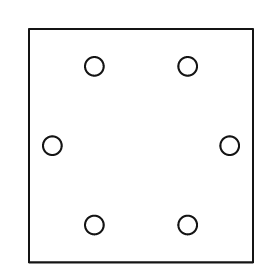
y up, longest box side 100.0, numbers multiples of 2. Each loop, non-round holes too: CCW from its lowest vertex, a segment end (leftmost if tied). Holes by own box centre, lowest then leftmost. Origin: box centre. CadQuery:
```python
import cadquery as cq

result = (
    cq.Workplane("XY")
    .moveTo(-48.0, -50.0)
    .lineTo(48.0, -50.0)
    .lineTo(48.0, 50.0)
    .lineTo(-48.0, 50.0)
    .close()
    .moveTo(-20.0, -34.0)
    .circle(4.0)
    .moveTo(20.0, -34.0)
    .circle(4.0)
    .moveTo(-38.0, 0.0)
    .circle(4.0)
    .moveTo(38.0, 0.0)
    .circle(4.0)
    .moveTo(-20.0, 34.0)
    .circle(4.0)
    .moveTo(20.0, 34.0)
    .circle(4.0)
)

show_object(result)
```